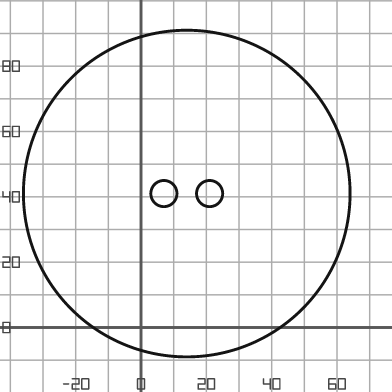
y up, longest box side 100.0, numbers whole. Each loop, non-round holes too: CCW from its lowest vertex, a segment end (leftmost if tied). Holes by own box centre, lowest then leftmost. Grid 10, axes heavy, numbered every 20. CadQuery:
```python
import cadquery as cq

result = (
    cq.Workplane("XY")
    .moveTo(14.0, 41.0)
    .circle(50.0)
    .moveTo(7.0, 41.0)
    .circle(4.0)
    .moveTo(21.0, 41.0)
    .circle(4.0)
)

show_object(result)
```